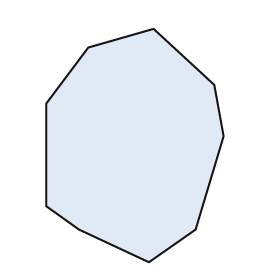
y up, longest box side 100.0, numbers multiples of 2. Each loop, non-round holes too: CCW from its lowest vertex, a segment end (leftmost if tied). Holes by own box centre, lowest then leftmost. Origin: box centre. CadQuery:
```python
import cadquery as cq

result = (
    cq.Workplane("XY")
    .moveTo(6.0, -50.0)
    .lineTo(26.0, -36.0)
    .lineTo(38.0, 4.0)
    .lineTo(34.0, 26.0)
    .lineTo(8.0, 50.0)
    .lineTo(-20.0, 42.0)
    .lineTo(-38.0, 18.0)
    .lineTo(-38.0, -26.0)
    .lineTo(-24.0, -36.0)
    .close()
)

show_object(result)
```